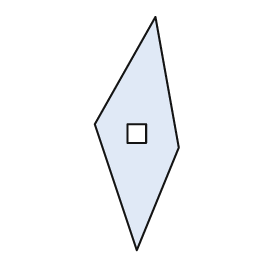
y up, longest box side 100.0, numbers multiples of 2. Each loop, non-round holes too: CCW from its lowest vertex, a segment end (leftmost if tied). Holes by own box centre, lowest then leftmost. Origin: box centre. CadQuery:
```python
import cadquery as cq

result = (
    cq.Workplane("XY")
    .moveTo(0.0, -50.0)
    .lineTo(18.0, -6.0)
    .lineTo(8.0, 50.0)
    .lineTo(-18.0, 4.0)
    .close()
    .moveTo(-4.0, -4.0)
    .lineTo(4.0, -4.0)
    .lineTo(4.0, 4.0)
    .lineTo(-4.0, 4.0)
    .close()
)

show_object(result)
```